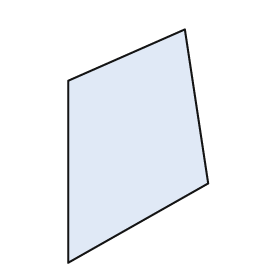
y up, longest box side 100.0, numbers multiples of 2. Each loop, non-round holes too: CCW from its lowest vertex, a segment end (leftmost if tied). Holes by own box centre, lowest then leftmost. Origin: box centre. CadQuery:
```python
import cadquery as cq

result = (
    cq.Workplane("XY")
    .moveTo(-30.0, -50.0)
    .lineTo(30.0, -16.0)
    .lineTo(20.0, 50.0)
    .lineTo(-30.0, 28.0)
    .close()
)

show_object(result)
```